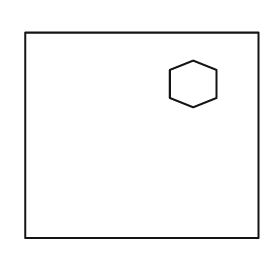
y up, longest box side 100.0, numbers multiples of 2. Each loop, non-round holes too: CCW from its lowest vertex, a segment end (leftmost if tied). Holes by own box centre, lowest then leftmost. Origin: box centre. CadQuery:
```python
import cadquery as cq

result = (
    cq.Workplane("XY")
    .moveTo(-50.0, -44.0)
    .lineTo(50.0, -44.0)
    .lineTo(50.0, 44.0)
    .lineTo(-50.0, 44.0)
    .close()
    .moveTo(22.0, 12.0)
    .lineTo(32.0, 16.0)
    .lineTo(32.0, 28.0)
    .lineTo(22.0, 32.0)
    .lineTo(12.0, 28.0)
    .lineTo(12.0, 16.0)
    .close()
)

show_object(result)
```